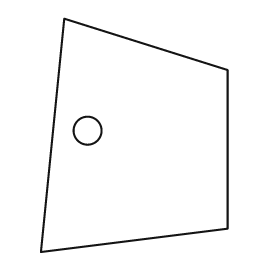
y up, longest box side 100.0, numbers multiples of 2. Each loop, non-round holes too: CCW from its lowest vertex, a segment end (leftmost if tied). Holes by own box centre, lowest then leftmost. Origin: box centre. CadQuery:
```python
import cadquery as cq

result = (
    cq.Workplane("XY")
    .moveTo(-40.0, -50.0)
    .lineTo(40.0, -40.0)
    .lineTo(40.0, 28.0)
    .lineTo(-30.0, 50.0)
    .close()
    .moveTo(-20.0, 2.0)
    .circle(6.0)
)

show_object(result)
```